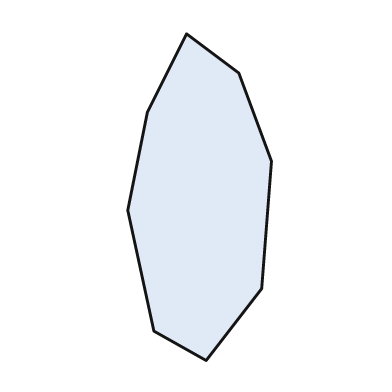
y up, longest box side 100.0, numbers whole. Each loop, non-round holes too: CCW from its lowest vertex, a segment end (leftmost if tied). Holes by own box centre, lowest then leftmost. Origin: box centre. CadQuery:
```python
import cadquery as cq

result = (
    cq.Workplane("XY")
    .moveTo(2.0, -50.0)
    .lineTo(19.0, -28.0)
    .lineTo(22.0, 11.0)
    .lineTo(12.0, 38.0)
    .lineTo(-4.0, 50.0)
    .lineTo(-16.0, 26.0)
    .lineTo(-22.0, -4.0)
    .lineTo(-14.0, -41.0)
    .close()
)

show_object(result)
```